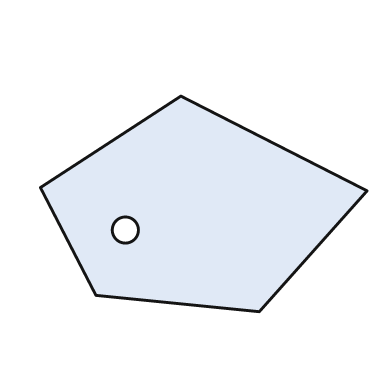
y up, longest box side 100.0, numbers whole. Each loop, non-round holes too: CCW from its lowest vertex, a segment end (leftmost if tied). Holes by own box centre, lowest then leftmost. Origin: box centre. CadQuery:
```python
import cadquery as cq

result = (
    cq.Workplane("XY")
    .moveTo(17.0, -33.0)
    .lineTo(50.0, 4.0)
    .lineTo(-7.0, 33.0)
    .lineTo(-50.0, 5.0)
    .lineTo(-33.0, -28.0)
    .close()
    .moveTo(-24.0, -8.0)
    .circle(4.0)
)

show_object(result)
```